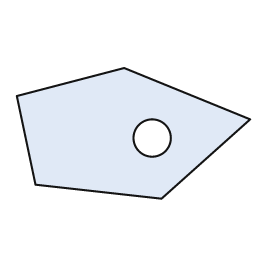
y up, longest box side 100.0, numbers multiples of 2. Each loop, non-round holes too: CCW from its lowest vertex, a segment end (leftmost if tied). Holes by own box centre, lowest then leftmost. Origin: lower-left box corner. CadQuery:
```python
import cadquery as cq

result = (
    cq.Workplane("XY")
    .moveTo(62.0, 0.0)
    .lineTo(100.0, 34.0)
    .lineTo(46.0, 56.0)
    .lineTo(0.0, 44.0)
    .lineTo(8.0, 6.0)
    .close()
    .moveTo(58.0, 26.0)
    .circle(8.0)
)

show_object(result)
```